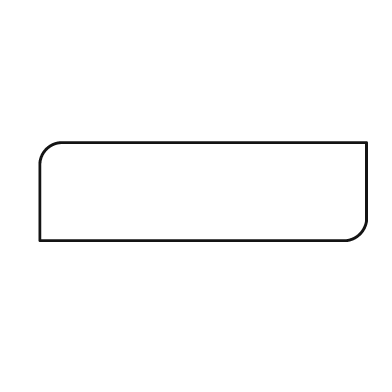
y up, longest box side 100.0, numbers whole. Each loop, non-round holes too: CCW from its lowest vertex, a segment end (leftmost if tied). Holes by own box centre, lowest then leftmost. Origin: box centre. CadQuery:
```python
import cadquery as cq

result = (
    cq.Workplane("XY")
    .moveTo(-50.0, -15.0)
    .lineTo(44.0, -15.0)
    .threePointArc((48.0, -13.0), (50.0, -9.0))
    .lineTo(50.0, 15.0)
    .lineTo(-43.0, 15.0)
    .threePointArc((-48.0, 13.0), (-50.0, 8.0))
    .close()
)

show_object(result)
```